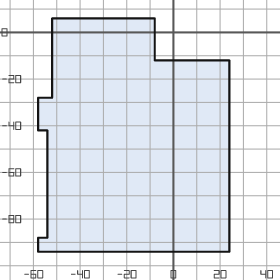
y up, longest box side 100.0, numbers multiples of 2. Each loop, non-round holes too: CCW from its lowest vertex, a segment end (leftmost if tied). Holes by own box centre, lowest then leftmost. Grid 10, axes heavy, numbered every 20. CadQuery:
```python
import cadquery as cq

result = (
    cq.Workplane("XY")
    .moveTo(-58.0, -94.0)
    .lineTo(24.0, -94.0)
    .lineTo(24.0, -12.0)
    .lineTo(-8.0, -12.0)
    .lineTo(-8.0, 6.0)
    .lineTo(-52.0, 6.0)
    .lineTo(-52.0, -28.0)
    .lineTo(-58.0, -28.0)
    .lineTo(-58.0, -42.0)
    .lineTo(-54.0, -42.0)
    .lineTo(-54.0, -88.0)
    .lineTo(-58.0, -88.0)
    .close()
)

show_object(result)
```